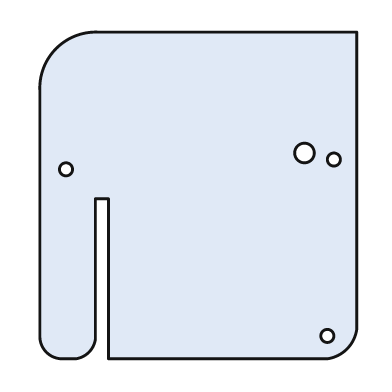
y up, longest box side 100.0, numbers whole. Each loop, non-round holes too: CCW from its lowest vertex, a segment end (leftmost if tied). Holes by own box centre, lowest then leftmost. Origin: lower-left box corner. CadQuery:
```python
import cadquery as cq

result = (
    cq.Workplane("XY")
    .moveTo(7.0, 0.0)
    .lineTo(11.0, 0.0)
    .threePointArc((15.0, 2.0), (17.0, 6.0))
    .lineTo(17.0, 49.0)
    .lineTo(21.0, 49.0)
    .lineTo(21.0, 0.0)
    .lineTo(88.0, 0.0)
    .threePointArc((94.0, 3.0), (97.0, 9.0))
    .lineTo(97.0, 100.0)
    .lineTo(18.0, 100.0)
    .threePointArc((5.0, 95.0), (0.0, 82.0))
    .lineTo(0.0, 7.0)
    .threePointArc((2.0, 2.0), (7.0, 0.0))
    .close()
    .moveTo(88.0, 7.0)
    .circle(2.0)
    .moveTo(8.0, 58.0)
    .circle(2.0)
    .moveTo(90.0, 61.0)
    .circle(2.0)
    .moveTo(81.0, 63.0)
    .circle(3.0)
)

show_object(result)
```